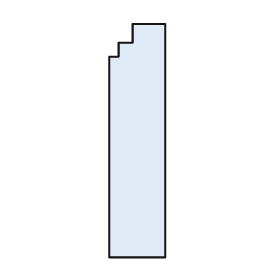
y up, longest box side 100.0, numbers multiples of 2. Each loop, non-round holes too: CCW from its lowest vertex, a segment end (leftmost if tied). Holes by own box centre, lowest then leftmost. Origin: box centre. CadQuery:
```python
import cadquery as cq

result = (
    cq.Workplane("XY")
    .moveTo(-12.0, -50.0)
    .lineTo(12.0, -50.0)
    .lineTo(12.0, 50.0)
    .lineTo(-2.0, 50.0)
    .lineTo(-2.0, 42.0)
    .lineTo(-8.0, 42.0)
    .lineTo(-8.0, 36.0)
    .lineTo(-12.0, 36.0)
    .close()
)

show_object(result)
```